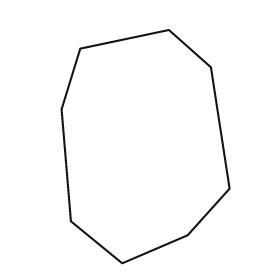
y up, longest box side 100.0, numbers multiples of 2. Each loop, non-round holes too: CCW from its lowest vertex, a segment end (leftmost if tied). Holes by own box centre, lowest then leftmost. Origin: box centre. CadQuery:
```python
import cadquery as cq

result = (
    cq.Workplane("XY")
    .moveTo(-10.0, -50.0)
    .lineTo(18.0, -38.0)
    .lineTo(36.0, -18.0)
    .lineTo(28.0, 34.0)
    .lineTo(10.0, 50.0)
    .lineTo(-28.0, 42.0)
    .lineTo(-36.0, 16.0)
    .lineTo(-32.0, -32.0)
    .close()
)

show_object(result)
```